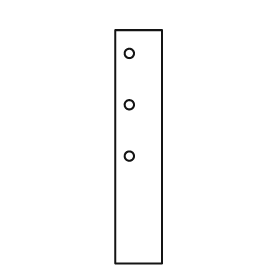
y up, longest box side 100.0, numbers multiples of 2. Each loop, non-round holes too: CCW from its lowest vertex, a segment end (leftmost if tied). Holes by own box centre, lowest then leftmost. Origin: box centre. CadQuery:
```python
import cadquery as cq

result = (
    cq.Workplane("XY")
    .moveTo(-10.0, -50.0)
    .lineTo(10.0, -50.0)
    .lineTo(10.0, 50.0)
    .lineTo(-10.0, 50.0)
    .close()
    .moveTo(-4.0, -4.0)
    .circle(2.0)
    .moveTo(-4.0, 18.0)
    .circle(2.0)
    .moveTo(-4.0, 40.0)
    .circle(2.0)
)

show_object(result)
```